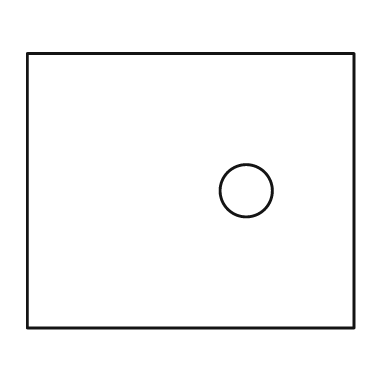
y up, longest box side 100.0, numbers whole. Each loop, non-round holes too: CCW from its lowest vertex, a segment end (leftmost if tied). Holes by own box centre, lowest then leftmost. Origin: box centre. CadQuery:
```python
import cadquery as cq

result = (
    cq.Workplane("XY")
    .moveTo(-50.0, -42.0)
    .lineTo(50.0, -42.0)
    .lineTo(50.0, 42.0)
    .lineTo(-50.0, 42.0)
    .close()
    .moveTo(17.0, 0.0)
    .circle(8.0)
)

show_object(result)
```